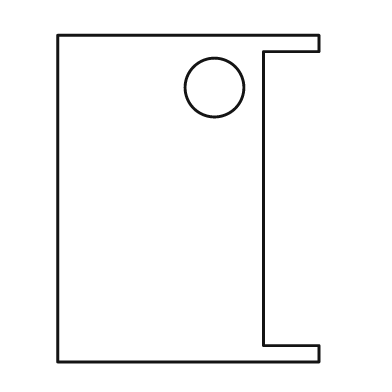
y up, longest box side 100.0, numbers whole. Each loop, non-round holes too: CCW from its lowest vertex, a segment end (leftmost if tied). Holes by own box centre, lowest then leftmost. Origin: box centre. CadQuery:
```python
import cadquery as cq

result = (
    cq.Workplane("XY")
    .moveTo(-40.0, -50.0)
    .lineTo(40.0, -50.0)
    .lineTo(40.0, -45.0)
    .lineTo(23.0, -45.0)
    .lineTo(23.0, 45.0)
    .lineTo(40.0, 45.0)
    .lineTo(40.0, 50.0)
    .lineTo(-40.0, 50.0)
    .close()
    .moveTo(8.0, 34.0)
    .circle(9.0)
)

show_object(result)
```